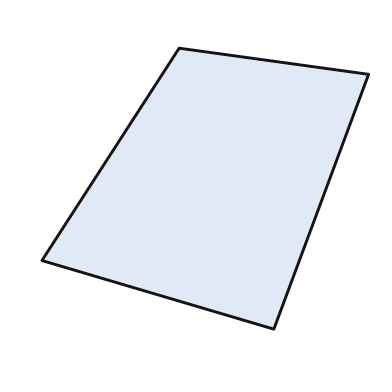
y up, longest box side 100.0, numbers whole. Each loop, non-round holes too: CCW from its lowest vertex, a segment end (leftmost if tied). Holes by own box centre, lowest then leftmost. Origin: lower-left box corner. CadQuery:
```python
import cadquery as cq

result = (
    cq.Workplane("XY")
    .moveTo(71.0, 0.0)
    .lineTo(100.0, 78.0)
    .lineTo(42.0, 86.0)
    .lineTo(0.0, 21.0)
    .close()
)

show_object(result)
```